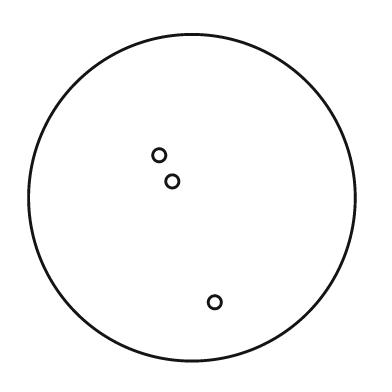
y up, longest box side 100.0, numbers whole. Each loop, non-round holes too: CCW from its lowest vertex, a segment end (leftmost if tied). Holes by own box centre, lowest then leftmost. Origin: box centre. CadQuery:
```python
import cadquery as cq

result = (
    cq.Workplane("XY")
    .moveTo(0.0, 0.0)
    .circle(50.0)
    .moveTo(7.0, -32.0)
    .circle(2.0)
    .moveTo(-6.0, 5.0)
    .circle(2.0)
    .moveTo(-10.0, 13.0)
    .circle(2.0)
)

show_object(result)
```